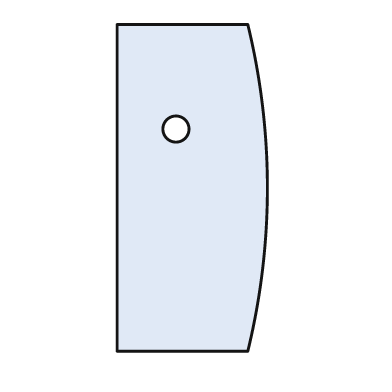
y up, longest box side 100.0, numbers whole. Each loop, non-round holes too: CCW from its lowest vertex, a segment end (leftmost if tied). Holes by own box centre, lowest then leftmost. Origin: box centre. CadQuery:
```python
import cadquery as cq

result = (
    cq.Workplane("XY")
    .moveTo(-23.0, -50.0)
    .lineTo(17.0, -50.0)
    .threePointArc((23.0, 0.0), (17.0, 50.0))
    .lineTo(-23.0, 50.0)
    .close()
    .moveTo(-5.0, 18.0)
    .circle(4.0)
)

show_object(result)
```